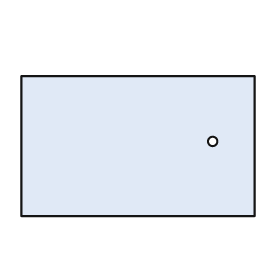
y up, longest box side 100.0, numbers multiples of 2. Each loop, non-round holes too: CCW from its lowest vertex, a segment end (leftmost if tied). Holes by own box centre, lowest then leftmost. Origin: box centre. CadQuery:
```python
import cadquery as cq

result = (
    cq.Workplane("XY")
    .moveTo(-50.0, -30.0)
    .lineTo(50.0, -30.0)
    .lineTo(50.0, 30.0)
    .lineTo(-50.0, 30.0)
    .close()
    .moveTo(32.0, 2.0)
    .circle(2.0)
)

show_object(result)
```